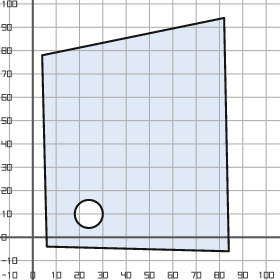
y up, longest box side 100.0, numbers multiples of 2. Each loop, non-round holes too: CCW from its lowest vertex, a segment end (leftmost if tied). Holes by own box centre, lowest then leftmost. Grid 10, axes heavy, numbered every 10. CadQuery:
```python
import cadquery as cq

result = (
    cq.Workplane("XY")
    .moveTo(84.0, -6.0)
    .lineTo(82.0, 94.0)
    .lineTo(4.0, 78.0)
    .lineTo(6.0, -4.0)
    .close()
    .moveTo(24.0, 10.0)
    .circle(6.0)
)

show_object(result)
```